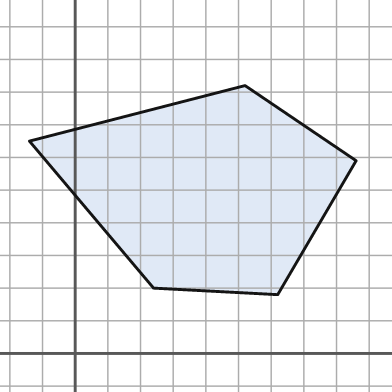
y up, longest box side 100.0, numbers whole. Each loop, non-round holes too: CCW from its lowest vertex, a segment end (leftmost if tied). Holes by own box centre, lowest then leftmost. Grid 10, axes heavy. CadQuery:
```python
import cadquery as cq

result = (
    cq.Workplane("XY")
    .moveTo(62.0, 18.0)
    .lineTo(86.0, 59.0)
    .lineTo(52.0, 82.0)
    .lineTo(-14.0, 65.0)
    .lineTo(24.0, 20.0)
    .close()
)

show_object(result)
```